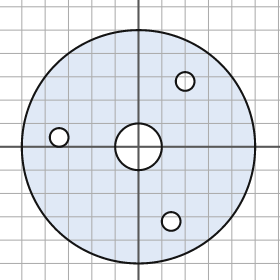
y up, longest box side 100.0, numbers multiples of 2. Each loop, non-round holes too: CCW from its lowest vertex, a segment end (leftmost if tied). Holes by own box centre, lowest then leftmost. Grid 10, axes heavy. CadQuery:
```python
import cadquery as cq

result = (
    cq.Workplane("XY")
    .moveTo(0.0, 0.0)
    .circle(50.0)
    .moveTo(14.0, -32.0)
    .circle(4.0)
    .moveTo(0.0, 0.0)
    .circle(10.0)
    .moveTo(-34.0, 4.0)
    .circle(4.0)
    .moveTo(20.0, 28.0)
    .circle(4.0)
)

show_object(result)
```